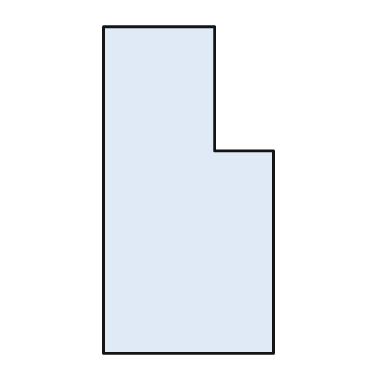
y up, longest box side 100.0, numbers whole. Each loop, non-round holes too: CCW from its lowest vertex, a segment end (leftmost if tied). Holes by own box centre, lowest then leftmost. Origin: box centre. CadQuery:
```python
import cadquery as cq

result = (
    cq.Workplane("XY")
    .moveTo(-26.0, -50.0)
    .lineTo(26.0, -50.0)
    .lineTo(26.0, 12.0)
    .lineTo(8.0, 12.0)
    .lineTo(8.0, 50.0)
    .lineTo(-26.0, 50.0)
    .close()
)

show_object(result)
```